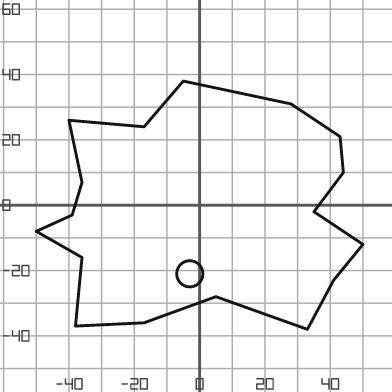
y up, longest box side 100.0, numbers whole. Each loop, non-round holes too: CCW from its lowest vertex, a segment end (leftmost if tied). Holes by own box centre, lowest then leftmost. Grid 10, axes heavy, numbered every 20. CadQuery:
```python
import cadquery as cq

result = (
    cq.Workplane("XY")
    .moveTo(33.0, -38.0)
    .lineTo(41.0, -23.0)
    .lineTo(50.0, -12.0)
    .lineTo(35.0, -2.0)
    .lineTo(44.0, 10.0)
    .lineTo(43.0, 21.0)
    .lineTo(28.0, 31.0)
    .lineTo(-5.0, 38.0)
    .lineTo(-17.0, 24.0)
    .lineTo(-40.0, 26.0)
    .lineTo(-36.0, 7.0)
    .lineTo(-39.0, -3.0)
    .lineTo(-50.0, -8.0)
    .lineTo(-36.0, -16.0)
    .lineTo(-38.0, -37.0)
    .lineTo(-17.0, -36.0)
    .lineTo(5.0, -28.0)
    .close()
    .moveTo(-3.0, -21.0)
    .circle(4.0)
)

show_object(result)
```